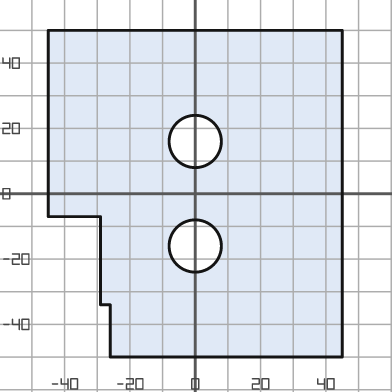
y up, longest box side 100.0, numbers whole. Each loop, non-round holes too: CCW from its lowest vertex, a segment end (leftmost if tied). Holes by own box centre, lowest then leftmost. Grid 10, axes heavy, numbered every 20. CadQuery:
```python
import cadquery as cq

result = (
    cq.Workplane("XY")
    .moveTo(-26.0, -50.0)
    .lineTo(45.0, -50.0)
    .lineTo(45.0, 50.0)
    .lineTo(-45.0, 50.0)
    .lineTo(-45.0, -7.0)
    .lineTo(-29.0, -7.0)
    .lineTo(-29.0, -34.0)
    .lineTo(-26.0, -34.0)
    .close()
    .moveTo(0.0, -16.0)
    .circle(8.0)
    .moveTo(0.0, 16.0)
    .circle(8.0)
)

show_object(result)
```